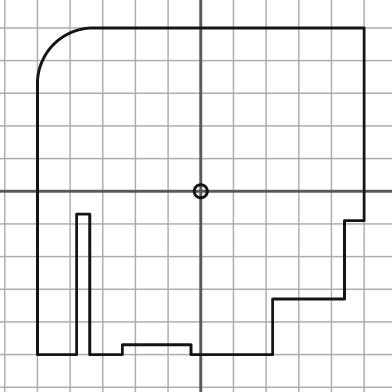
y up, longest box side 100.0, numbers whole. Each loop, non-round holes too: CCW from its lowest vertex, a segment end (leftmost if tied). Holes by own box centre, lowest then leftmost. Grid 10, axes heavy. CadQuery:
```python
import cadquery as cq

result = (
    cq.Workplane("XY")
    .moveTo(-50.0, -50.0)
    .lineTo(-38.0, -50.0)
    .lineTo(-38.0, -7.0)
    .lineTo(-34.0, -7.0)
    .lineTo(-34.0, -50.0)
    .lineTo(-24.0, -50.0)
    .lineTo(-24.0, -47.0)
    .lineTo(-3.0, -47.0)
    .lineTo(-3.0, -50.0)
    .lineTo(22.0, -50.0)
    .lineTo(22.0, -33.0)
    .lineTo(44.0, -33.0)
    .lineTo(44.0, -9.0)
    .lineTo(50.0, -9.0)
    .lineTo(50.0, 50.0)
    .lineTo(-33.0, 50.0)
    .threePointArc((-45.0, 45.0), (-50.0, 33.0))
    .close()
    .moveTo(0.0, 0.0)
    .circle(2.0)
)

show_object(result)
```